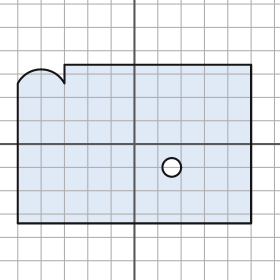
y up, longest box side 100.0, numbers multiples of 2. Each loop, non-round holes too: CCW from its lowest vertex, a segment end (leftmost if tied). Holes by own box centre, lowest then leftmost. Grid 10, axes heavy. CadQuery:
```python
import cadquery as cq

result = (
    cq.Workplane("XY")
    .moveTo(-50.0, -34.0)
    .lineTo(50.0, -34.0)
    .lineTo(50.0, 34.0)
    .lineTo(-30.0, 34.0)
    .lineTo(-30.0, 26.0)
    .threePointArc((-40.0, 32.0), (-50.0, 26.0))
    .close()
    .moveTo(16.0, -10.0)
    .circle(4.0)
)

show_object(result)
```